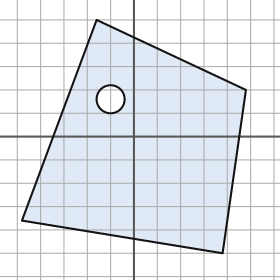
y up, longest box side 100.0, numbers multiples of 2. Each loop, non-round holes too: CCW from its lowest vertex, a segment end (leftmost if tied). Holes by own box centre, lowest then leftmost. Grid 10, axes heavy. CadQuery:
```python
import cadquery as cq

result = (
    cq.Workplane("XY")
    .moveTo(38.0, -50.0)
    .lineTo(48.0, 20.0)
    .lineTo(-16.0, 50.0)
    .lineTo(-48.0, -36.0)
    .close()
    .moveTo(-10.0, 16.0)
    .circle(6.0)
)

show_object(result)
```